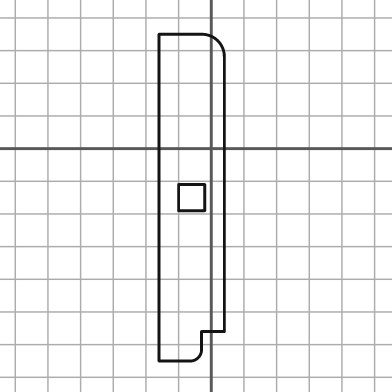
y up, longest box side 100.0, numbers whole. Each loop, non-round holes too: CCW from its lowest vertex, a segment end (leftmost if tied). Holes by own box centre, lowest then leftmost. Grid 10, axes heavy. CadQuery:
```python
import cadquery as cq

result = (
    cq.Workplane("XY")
    .moveTo(-16.0, -65.0)
    .lineTo(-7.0, -65.0)
    .threePointArc((-4.0, -64.0), (-3.0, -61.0))
    .lineTo(-3.0, -56.0)
    .lineTo(4.0, -56.0)
    .lineTo(4.0, 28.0)
    .threePointArc((2.0, 33.0), (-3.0, 35.0))
    .lineTo(-16.0, 35.0)
    .close()
    .moveTo(-10.0, -19.0)
    .lineTo(-2.0, -19.0)
    .lineTo(-2.0, -11.0)
    .lineTo(-10.0, -11.0)
    .close()
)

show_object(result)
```